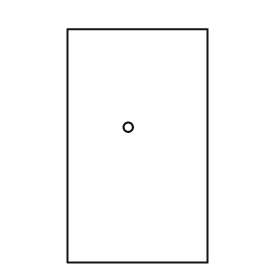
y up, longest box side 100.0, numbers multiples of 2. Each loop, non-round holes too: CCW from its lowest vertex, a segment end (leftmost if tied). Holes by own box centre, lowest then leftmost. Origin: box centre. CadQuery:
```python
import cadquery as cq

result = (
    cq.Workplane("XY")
    .moveTo(-30.0, -50.0)
    .lineTo(30.0, -50.0)
    .lineTo(30.0, 50.0)
    .lineTo(-30.0, 50.0)
    .close()
    .moveTo(-4.0, 8.0)
    .circle(2.0)
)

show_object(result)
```